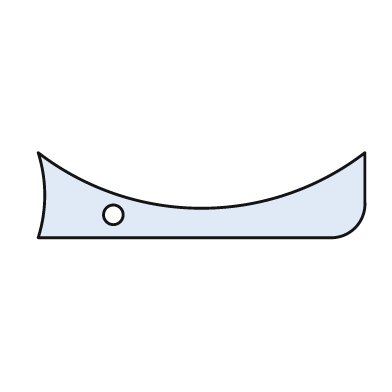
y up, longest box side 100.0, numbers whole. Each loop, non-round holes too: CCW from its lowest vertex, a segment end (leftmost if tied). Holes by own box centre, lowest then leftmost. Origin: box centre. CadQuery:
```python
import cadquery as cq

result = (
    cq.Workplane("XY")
    .moveTo(-50.0, -13.0)
    .lineTo(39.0, -13.0)
    .threePointArc((47.0, -10.0), (50.0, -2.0))
    .lineTo(50.0, 13.0)
    .threePointArc((0.0, -4.0), (-50.0, 13.0))
    .threePointArc((-48.0, 0.0), (-50.0, -13.0))
    .close()
    .moveTo(-27.0, -6.0)
    .circle(3.0)
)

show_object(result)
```